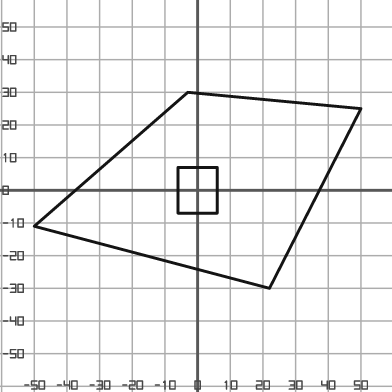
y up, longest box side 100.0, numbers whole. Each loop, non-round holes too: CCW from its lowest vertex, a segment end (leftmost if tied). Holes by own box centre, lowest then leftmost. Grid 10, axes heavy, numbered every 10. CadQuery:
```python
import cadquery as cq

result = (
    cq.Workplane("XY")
    .moveTo(22.0, -30.0)
    .lineTo(50.0, 25.0)
    .lineTo(-3.0, 30.0)
    .lineTo(-50.0, -11.0)
    .close()
    .moveTo(-6.0, -7.0)
    .lineTo(6.0, -7.0)
    .lineTo(6.0, 7.0)
    .lineTo(-6.0, 7.0)
    .close()
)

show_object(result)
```